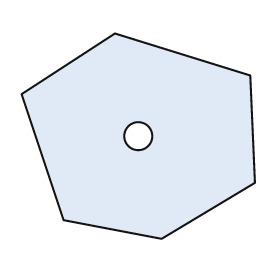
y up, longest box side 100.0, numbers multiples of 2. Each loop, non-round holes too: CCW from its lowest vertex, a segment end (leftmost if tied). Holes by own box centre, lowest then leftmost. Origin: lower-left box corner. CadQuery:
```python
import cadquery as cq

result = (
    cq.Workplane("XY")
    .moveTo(60.0, 0.0)
    .lineTo(100.0, 24.0)
    .lineTo(98.0, 70.0)
    .lineTo(40.0, 88.0)
    .lineTo(0.0, 62.0)
    .lineTo(18.0, 8.0)
    .close()
    .moveTo(50.0, 44.0)
    .circle(6.0)
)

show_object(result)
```